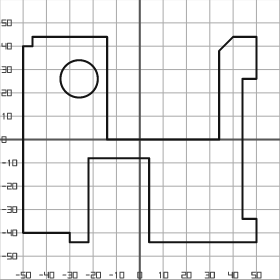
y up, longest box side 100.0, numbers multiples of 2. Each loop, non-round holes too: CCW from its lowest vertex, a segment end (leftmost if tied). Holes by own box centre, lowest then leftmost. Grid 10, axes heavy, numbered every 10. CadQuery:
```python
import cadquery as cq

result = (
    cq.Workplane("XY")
    .moveTo(-30.0, -44.0)
    .lineTo(-22.0, -44.0)
    .lineTo(-22.0, -8.0)
    .lineTo(4.0, -8.0)
    .lineTo(4.0, -44.0)
    .lineTo(50.0, -44.0)
    .lineTo(50.0, -34.0)
    .lineTo(44.0, -34.0)
    .lineTo(44.0, 26.0)
    .lineTo(50.0, 26.0)
    .lineTo(50.0, 44.0)
    .lineTo(40.0, 44.0)
    .lineTo(34.0, 38.0)
    .lineTo(34.0, 0.0)
    .lineTo(-14.0, 0.0)
    .lineTo(-14.0, 44.0)
    .lineTo(-46.0, 44.0)
    .lineTo(-46.0, 40.0)
    .lineTo(-50.0, 40.0)
    .lineTo(-50.0, -40.0)
    .lineTo(-30.0, -40.0)
    .close()
    .moveTo(-26.0, 26.0)
    .circle(8.0)
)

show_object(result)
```